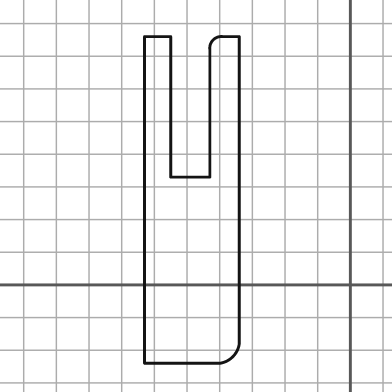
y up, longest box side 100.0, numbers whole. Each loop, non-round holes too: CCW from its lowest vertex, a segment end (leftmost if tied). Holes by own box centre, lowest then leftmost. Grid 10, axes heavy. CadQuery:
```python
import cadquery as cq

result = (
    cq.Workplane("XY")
    .moveTo(-63.0, -24.0)
    .lineTo(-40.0, -24.0)
    .threePointArc((-36.0, -22.0), (-34.0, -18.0))
    .lineTo(-34.0, 76.0)
    .lineTo(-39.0, 76.0)
    .threePointArc((-42.0, 75.0), (-43.0, 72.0))
    .lineTo(-43.0, 33.0)
    .lineTo(-55.0, 33.0)
    .lineTo(-55.0, 76.0)
    .lineTo(-63.0, 76.0)
    .close()
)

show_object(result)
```